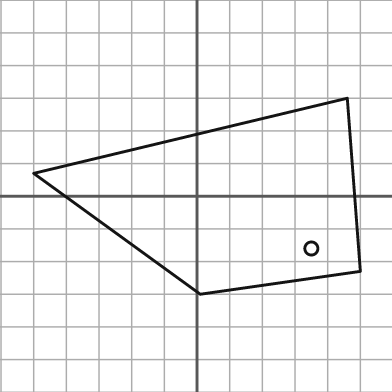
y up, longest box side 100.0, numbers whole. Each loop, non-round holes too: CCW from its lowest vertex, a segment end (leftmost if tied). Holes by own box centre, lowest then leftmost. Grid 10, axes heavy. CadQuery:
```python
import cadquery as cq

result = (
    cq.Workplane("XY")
    .moveTo(1.0, -30.0)
    .lineTo(50.0, -23.0)
    .lineTo(46.0, 30.0)
    .lineTo(-50.0, 7.0)
    .close()
    .moveTo(35.0, -16.0)
    .circle(2.0)
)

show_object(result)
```